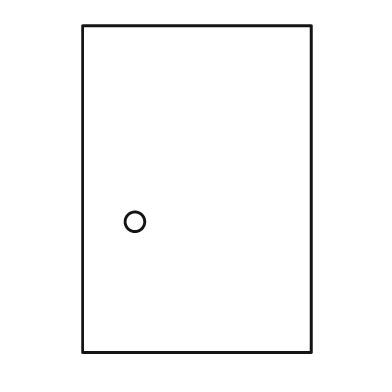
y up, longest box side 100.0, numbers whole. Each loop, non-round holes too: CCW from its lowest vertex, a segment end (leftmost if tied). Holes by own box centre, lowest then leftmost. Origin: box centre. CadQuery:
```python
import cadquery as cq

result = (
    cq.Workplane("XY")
    .moveTo(-35.0, -50.0)
    .lineTo(35.0, -50.0)
    .lineTo(35.0, 50.0)
    .lineTo(-35.0, 50.0)
    .close()
    .moveTo(-19.0, -10.0)
    .circle(3.0)
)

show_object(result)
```